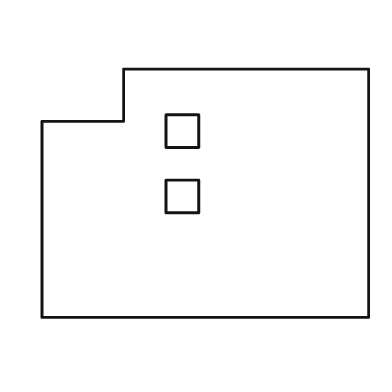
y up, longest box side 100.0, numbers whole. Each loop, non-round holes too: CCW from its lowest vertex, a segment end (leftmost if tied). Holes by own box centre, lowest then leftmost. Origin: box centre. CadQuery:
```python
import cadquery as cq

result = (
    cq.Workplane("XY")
    .moveTo(-50.0, -38.0)
    .lineTo(50.0, -38.0)
    .lineTo(50.0, 38.0)
    .lineTo(-25.0, 38.0)
    .lineTo(-25.0, 22.0)
    .lineTo(-50.0, 22.0)
    .close()
    .moveTo(-12.0, -6.0)
    .lineTo(-2.0, -6.0)
    .lineTo(-2.0, 4.0)
    .lineTo(-12.0, 4.0)
    .close()
    .moveTo(-12.0, 14.0)
    .lineTo(-2.0, 14.0)
    .lineTo(-2.0, 24.0)
    .lineTo(-12.0, 24.0)
    .close()
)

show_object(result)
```